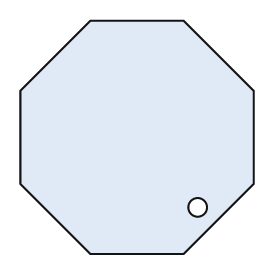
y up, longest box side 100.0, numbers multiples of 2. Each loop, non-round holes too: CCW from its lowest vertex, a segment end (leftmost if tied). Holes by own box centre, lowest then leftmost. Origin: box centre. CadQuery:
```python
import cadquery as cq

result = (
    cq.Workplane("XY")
    .moveTo(-20.0, -50.0)
    .lineTo(20.0, -50.0)
    .lineTo(50.0, -20.0)
    .lineTo(50.0, 20.0)
    .lineTo(20.0, 50.0)
    .lineTo(-20.0, 50.0)
    .lineTo(-50.0, 20.0)
    .lineTo(-50.0, -20.0)
    .close()
    .moveTo(26.0, -30.0)
    .circle(4.0)
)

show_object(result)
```